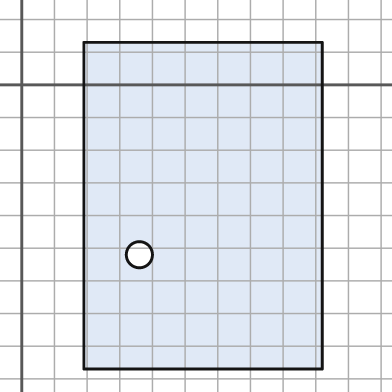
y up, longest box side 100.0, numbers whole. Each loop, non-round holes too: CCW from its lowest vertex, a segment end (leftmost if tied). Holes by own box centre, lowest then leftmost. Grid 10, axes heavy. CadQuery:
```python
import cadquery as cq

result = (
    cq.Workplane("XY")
    .moveTo(19.0, -87.0)
    .lineTo(92.0, -87.0)
    .lineTo(92.0, 13.0)
    .lineTo(19.0, 13.0)
    .close()
    .moveTo(36.0, -52.0)
    .circle(4.0)
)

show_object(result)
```